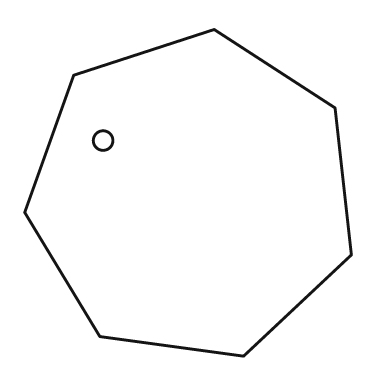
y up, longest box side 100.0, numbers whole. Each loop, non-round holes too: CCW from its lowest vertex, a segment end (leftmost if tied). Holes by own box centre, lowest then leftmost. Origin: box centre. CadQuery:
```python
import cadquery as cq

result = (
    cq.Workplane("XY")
    .moveTo(17.0, -50.0)
    .lineTo(50.0, -19.0)
    .lineTo(45.0, 26.0)
    .lineTo(8.0, 50.0)
    .lineTo(-35.0, 36.0)
    .lineTo(-50.0, -6.0)
    .lineTo(-27.0, -44.0)
    .close()
    .moveTo(-26.0, 16.0)
    .circle(3.0)
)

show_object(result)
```